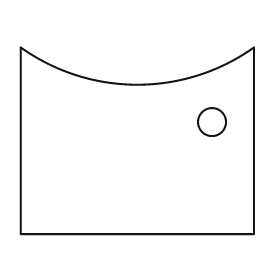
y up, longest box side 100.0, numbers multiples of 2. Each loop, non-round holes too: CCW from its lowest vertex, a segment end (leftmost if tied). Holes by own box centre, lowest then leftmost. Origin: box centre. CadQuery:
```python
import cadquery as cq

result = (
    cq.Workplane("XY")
    .moveTo(-50.0, -40.0)
    .lineTo(50.0, -40.0)
    .lineTo(50.0, 40.0)
    .threePointArc((0.0, 24.0), (-50.0, 40.0))
    .close()
    .moveTo(32.0, 8.0)
    .circle(6.0)
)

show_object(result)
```